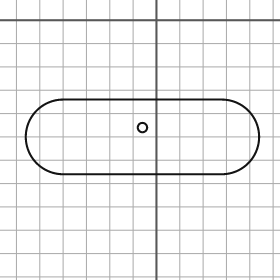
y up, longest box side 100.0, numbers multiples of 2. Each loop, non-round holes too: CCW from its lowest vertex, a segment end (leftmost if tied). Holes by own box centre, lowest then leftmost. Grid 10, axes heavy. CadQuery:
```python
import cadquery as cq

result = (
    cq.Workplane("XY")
    .moveTo(-40.0, -66.0)
    .lineTo(28.0, -66.0)
    .threePointArc((44.0, -50.0), (28.0, -34.0))
    .lineTo(-40.0, -34.0)
    .threePointArc((-56.0, -50.0), (-40.0, -66.0))
    .close()
    .moveTo(-6.0, -46.0)
    .circle(2.0)
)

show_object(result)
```